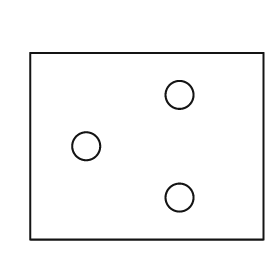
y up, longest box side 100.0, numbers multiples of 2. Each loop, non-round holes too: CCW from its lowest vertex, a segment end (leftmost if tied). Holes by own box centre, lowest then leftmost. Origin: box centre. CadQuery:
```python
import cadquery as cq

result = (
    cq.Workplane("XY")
    .moveTo(-50.0, -40.0)
    .lineTo(50.0, -40.0)
    .lineTo(50.0, 40.0)
    .lineTo(-50.0, 40.0)
    .close()
    .moveTo(14.0, -22.0)
    .circle(6.0)
    .moveTo(-26.0, 0.0)
    .circle(6.0)
    .moveTo(14.0, 22.0)
    .circle(6.0)
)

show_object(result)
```